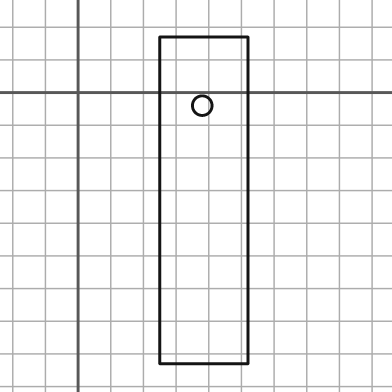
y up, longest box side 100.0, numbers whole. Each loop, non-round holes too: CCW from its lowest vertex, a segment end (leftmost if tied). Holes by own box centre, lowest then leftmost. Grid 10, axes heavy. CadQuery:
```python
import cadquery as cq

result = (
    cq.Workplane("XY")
    .moveTo(25.0, -83.0)
    .lineTo(52.0, -83.0)
    .lineTo(52.0, 17.0)
    .lineTo(25.0, 17.0)
    .close()
    .moveTo(38.0, -4.0)
    .circle(3.0)
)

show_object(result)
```